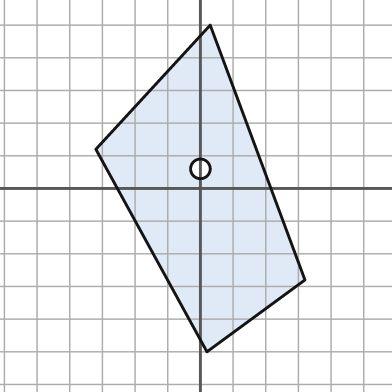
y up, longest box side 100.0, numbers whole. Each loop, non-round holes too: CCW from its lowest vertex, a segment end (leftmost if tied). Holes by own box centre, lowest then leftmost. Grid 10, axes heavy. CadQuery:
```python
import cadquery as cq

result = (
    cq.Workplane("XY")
    .moveTo(2.0, -50.0)
    .lineTo(32.0, -28.0)
    .lineTo(3.0, 50.0)
    .lineTo(-32.0, 12.0)
    .close()
    .moveTo(0.0, 6.0)
    .circle(3.0)
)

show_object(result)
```